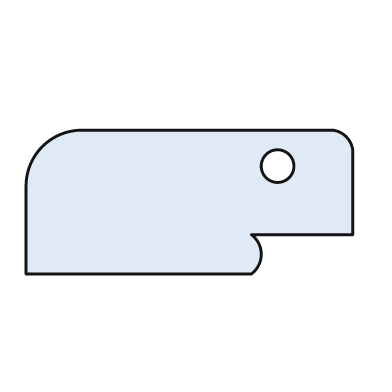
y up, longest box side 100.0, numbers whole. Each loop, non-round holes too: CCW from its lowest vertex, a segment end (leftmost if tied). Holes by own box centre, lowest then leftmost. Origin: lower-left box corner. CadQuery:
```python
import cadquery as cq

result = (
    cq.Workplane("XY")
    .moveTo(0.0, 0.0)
    .lineTo(69.0, 0.0)
    .threePointArc((72.0, 6.0), (69.0, 12.0))
    .lineTo(100.0, 12.0)
    .lineTo(100.0, 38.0)
    .threePointArc((98.0, 42.0), (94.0, 44.0))
    .lineTo(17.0, 44.0)
    .threePointArc((5.0, 39.0), (0.0, 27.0))
    .close()
    .moveTo(77.0, 33.0)
    .circle(5.0)
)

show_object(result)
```